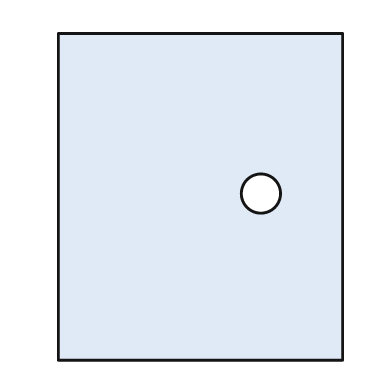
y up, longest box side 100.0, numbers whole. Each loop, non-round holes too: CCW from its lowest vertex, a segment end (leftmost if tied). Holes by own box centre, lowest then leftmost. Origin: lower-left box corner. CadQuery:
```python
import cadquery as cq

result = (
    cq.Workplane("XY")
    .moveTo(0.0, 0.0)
    .lineTo(87.0, 0.0)
    .lineTo(87.0, 100.0)
    .lineTo(0.0, 100.0)
    .close()
    .moveTo(62.0, 51.0)
    .circle(6.0)
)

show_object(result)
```